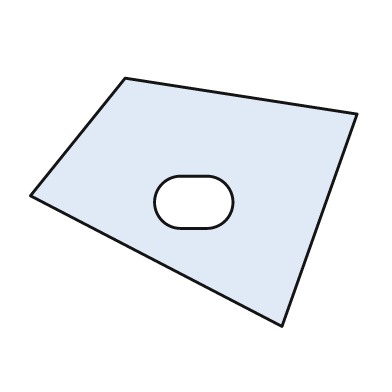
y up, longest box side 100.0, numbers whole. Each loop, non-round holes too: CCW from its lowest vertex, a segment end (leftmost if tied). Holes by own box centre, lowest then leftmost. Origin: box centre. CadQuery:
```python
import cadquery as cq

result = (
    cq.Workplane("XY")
    .moveTo(27.0, -38.0)
    .lineTo(50.0, 27.0)
    .lineTo(-21.0, 38.0)
    .lineTo(-50.0, 2.0)
    .close()
    .moveTo(-4.0, -8.0)
    .lineTo(4.0, -8.0)
    .threePointArc((12.0, 0.0), (4.0, 8.0))
    .lineTo(-4.0, 8.0)
    .threePointArc((-12.0, 0.0), (-4.0, -8.0))
    .close()
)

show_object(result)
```